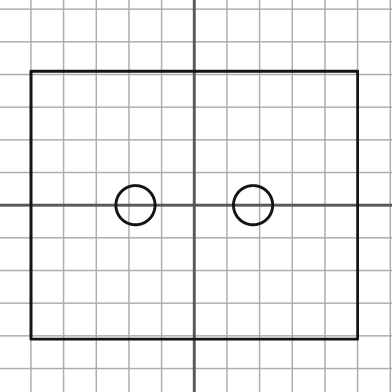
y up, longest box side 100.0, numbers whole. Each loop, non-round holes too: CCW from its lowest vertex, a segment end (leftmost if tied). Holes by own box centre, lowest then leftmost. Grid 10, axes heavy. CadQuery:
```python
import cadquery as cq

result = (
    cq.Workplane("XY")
    .moveTo(-50.0, -41.0)
    .lineTo(50.0, -41.0)
    .lineTo(50.0, 41.0)
    .lineTo(-50.0, 41.0)
    .close()
    .moveTo(-18.0, 0.0)
    .circle(6.0)
    .moveTo(18.0, 0.0)
    .circle(6.0)
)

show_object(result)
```